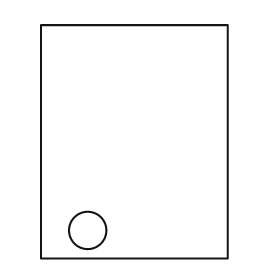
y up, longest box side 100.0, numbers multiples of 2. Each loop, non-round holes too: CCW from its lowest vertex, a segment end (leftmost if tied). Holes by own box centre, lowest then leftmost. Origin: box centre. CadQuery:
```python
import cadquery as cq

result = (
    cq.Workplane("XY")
    .moveTo(-40.0, -50.0)
    .lineTo(40.0, -50.0)
    .lineTo(40.0, 50.0)
    .lineTo(-40.0, 50.0)
    .close()
    .moveTo(-20.0, -38.0)
    .circle(8.0)
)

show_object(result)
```